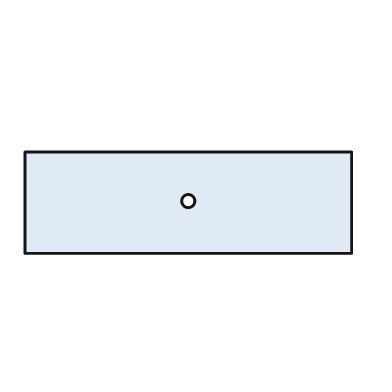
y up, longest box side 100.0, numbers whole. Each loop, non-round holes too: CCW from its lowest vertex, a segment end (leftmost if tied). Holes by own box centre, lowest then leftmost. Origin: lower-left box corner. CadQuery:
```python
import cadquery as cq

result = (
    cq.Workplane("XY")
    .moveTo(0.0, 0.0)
    .lineTo(100.0, 0.0)
    .lineTo(100.0, 31.0)
    .lineTo(0.0, 31.0)
    .close()
    .moveTo(50.0, 16.0)
    .circle(2.0)
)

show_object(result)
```